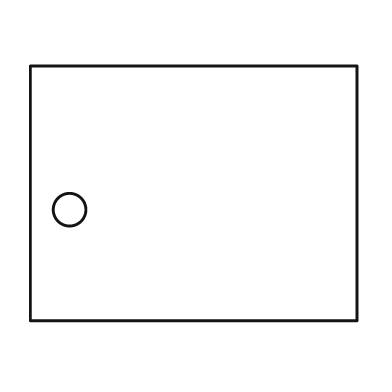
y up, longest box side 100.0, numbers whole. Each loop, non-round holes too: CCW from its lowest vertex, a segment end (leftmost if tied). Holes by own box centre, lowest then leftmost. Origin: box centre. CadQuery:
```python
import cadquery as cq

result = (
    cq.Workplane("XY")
    .moveTo(-50.0, -39.0)
    .lineTo(50.0, -39.0)
    .lineTo(50.0, 39.0)
    .lineTo(-50.0, 39.0)
    .close()
    .moveTo(-38.0, -5.0)
    .circle(5.0)
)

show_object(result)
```